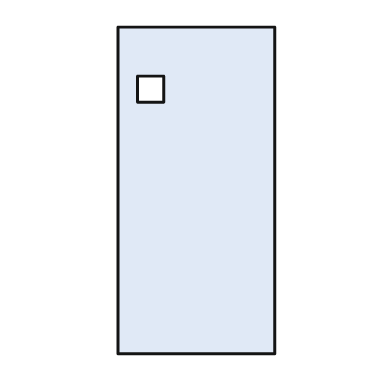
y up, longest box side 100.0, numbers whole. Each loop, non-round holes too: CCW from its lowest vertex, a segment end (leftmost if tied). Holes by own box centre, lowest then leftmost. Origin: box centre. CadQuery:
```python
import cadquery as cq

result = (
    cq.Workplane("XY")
    .moveTo(-24.0, -50.0)
    .lineTo(24.0, -50.0)
    .lineTo(24.0, 50.0)
    .lineTo(-24.0, 50.0)
    .close()
    .moveTo(-18.0, 27.0)
    .lineTo(-10.0, 27.0)
    .lineTo(-10.0, 35.0)
    .lineTo(-18.0, 35.0)
    .close()
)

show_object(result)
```